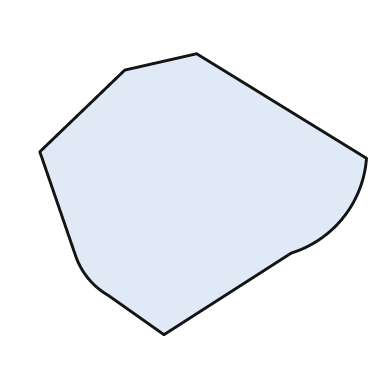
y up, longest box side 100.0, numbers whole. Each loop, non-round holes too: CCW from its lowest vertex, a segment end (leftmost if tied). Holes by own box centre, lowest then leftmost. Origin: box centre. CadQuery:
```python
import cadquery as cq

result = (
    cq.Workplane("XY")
    .moveTo(-12.0, -43.0)
    .lineTo(27.0, -18.0)
    .threePointArc((43.0, -7.0), (50.0, 11.0))
    .lineTo(-2.0, 43.0)
    .lineTo(-24.0, 38.0)
    .lineTo(-50.0, 13.0)
    .lineTo(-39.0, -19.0)
    .threePointArc((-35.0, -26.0), (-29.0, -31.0))
    .close()
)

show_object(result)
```